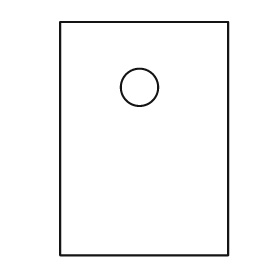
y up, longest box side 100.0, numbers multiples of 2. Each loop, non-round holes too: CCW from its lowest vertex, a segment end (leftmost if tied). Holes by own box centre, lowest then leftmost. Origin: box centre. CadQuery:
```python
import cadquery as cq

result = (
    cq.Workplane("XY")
    .moveTo(-36.0, -50.0)
    .lineTo(36.0, -50.0)
    .lineTo(36.0, 50.0)
    .lineTo(-36.0, 50.0)
    .close()
    .moveTo(-2.0, 22.0)
    .circle(8.0)
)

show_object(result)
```